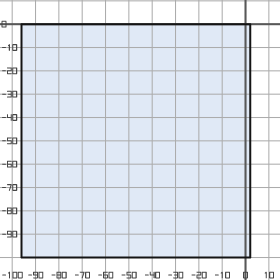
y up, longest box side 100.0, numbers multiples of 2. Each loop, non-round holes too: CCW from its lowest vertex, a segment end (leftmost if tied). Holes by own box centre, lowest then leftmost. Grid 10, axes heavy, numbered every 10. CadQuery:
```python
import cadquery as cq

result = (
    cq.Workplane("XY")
    .moveTo(-96.0, -100.0)
    .lineTo(2.0, -100.0)
    .lineTo(2.0, 0.0)
    .lineTo(-96.0, 0.0)
    .close()
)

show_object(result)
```